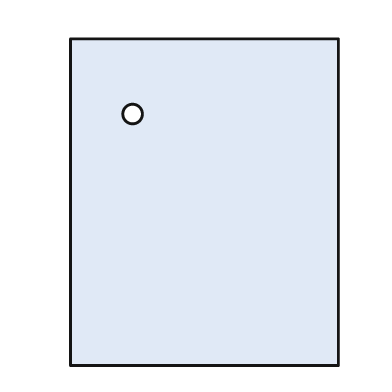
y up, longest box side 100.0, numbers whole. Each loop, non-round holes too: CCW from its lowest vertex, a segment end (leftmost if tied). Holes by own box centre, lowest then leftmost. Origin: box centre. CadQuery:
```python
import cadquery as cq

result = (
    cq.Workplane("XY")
    .moveTo(-41.0, -50.0)
    .lineTo(41.0, -50.0)
    .lineTo(41.0, 50.0)
    .lineTo(-41.0, 50.0)
    .close()
    .moveTo(-22.0, 27.0)
    .circle(3.0)
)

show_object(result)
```